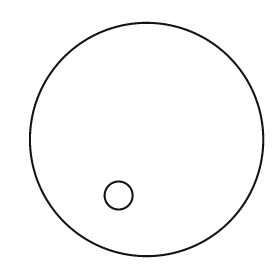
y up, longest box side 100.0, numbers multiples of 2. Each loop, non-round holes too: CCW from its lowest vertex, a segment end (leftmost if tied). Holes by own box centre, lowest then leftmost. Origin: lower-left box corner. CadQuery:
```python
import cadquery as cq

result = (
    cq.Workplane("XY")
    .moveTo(50.0, 50.0)
    .circle(50.0)
    .moveTo(38.0, 26.0)
    .circle(6.0)
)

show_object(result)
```